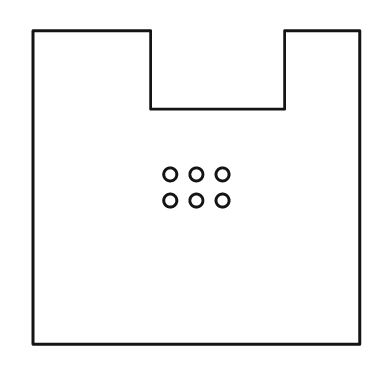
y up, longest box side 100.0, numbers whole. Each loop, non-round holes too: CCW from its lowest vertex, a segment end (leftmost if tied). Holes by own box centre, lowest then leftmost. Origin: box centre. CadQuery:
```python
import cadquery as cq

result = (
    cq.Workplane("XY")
    .moveTo(-50.0, -48.0)
    .lineTo(50.0, -48.0)
    .lineTo(50.0, 48.0)
    .lineTo(27.0, 48.0)
    .lineTo(27.0, 24.0)
    .lineTo(-14.0, 24.0)
    .lineTo(-14.0, 48.0)
    .lineTo(-50.0, 48.0)
    .close()
    .moveTo(-8.0, -4.0)
    .circle(2.0)
    .moveTo(0.0, -4.0)
    .circle(2.0)
    .moveTo(8.0, -4.0)
    .circle(2.0)
    .moveTo(-8.0, 4.0)
    .circle(2.0)
    .moveTo(0.0, 4.0)
    .circle(2.0)
    .moveTo(8.0, 4.0)
    .circle(2.0)
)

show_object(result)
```